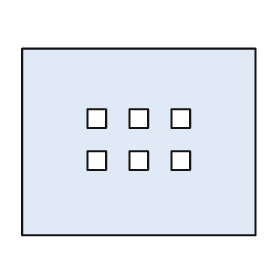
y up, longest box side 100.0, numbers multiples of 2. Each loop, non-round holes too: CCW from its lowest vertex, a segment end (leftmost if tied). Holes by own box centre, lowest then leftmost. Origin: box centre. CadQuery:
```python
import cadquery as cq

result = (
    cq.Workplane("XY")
    .moveTo(-50.0, -40.0)
    .lineTo(50.0, -40.0)
    .lineTo(50.0, 40.0)
    .lineTo(-50.0, 40.0)
    .close()
    .moveTo(-22.0, -12.0)
    .lineTo(-14.0, -12.0)
    .lineTo(-14.0, -4.0)
    .lineTo(-22.0, -4.0)
    .close()
    .moveTo(-4.0, -12.0)
    .lineTo(4.0, -12.0)
    .lineTo(4.0, -4.0)
    .lineTo(-4.0, -4.0)
    .close()
    .moveTo(14.0, -12.0)
    .lineTo(22.0, -12.0)
    .lineTo(22.0, -4.0)
    .lineTo(14.0, -4.0)
    .close()
    .moveTo(-22.0, 6.0)
    .lineTo(-14.0, 6.0)
    .lineTo(-14.0, 14.0)
    .lineTo(-22.0, 14.0)
    .close()
    .moveTo(-4.0, 6.0)
    .lineTo(4.0, 6.0)
    .lineTo(4.0, 14.0)
    .lineTo(-4.0, 14.0)
    .close()
    .moveTo(14.0, 6.0)
    .lineTo(22.0, 6.0)
    .lineTo(22.0, 14.0)
    .lineTo(14.0, 14.0)
    .close()
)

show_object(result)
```